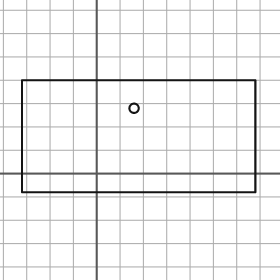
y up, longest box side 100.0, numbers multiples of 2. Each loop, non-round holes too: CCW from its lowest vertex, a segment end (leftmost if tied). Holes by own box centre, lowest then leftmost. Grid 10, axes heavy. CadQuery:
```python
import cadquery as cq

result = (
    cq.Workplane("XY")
    .moveTo(-32.0, -8.0)
    .lineTo(68.0, -8.0)
    .lineTo(68.0, 40.0)
    .lineTo(-32.0, 40.0)
    .close()
    .moveTo(16.0, 28.0)
    .circle(2.0)
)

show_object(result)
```